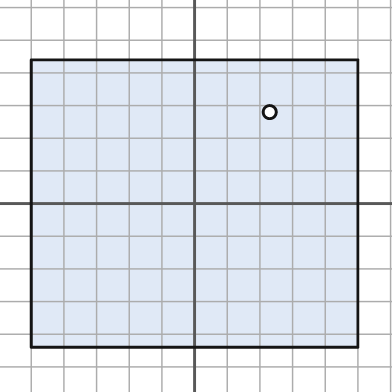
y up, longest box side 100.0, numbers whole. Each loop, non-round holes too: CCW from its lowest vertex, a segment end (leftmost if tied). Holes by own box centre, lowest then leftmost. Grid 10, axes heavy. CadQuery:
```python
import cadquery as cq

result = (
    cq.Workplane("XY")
    .moveTo(-50.0, -44.0)
    .lineTo(50.0, -44.0)
    .lineTo(50.0, 44.0)
    .lineTo(-50.0, 44.0)
    .close()
    .moveTo(23.0, 28.0)
    .circle(2.0)
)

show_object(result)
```